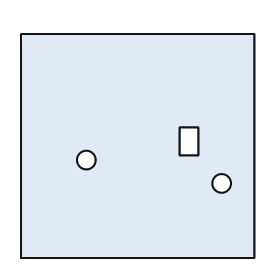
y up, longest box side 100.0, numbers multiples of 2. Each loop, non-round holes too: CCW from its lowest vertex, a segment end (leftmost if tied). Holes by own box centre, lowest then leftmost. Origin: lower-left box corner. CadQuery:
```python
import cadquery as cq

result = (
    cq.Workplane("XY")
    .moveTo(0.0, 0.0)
    .lineTo(100.0, 0.0)
    .lineTo(100.0, 96.0)
    .lineTo(0.0, 96.0)
    .close()
    .moveTo(86.0, 32.0)
    .circle(4.0)
    .moveTo(28.0, 42.0)
    .circle(4.0)
    .moveTo(68.0, 44.0)
    .lineTo(76.0, 44.0)
    .lineTo(76.0, 56.0)
    .lineTo(68.0, 56.0)
    .close()
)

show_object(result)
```